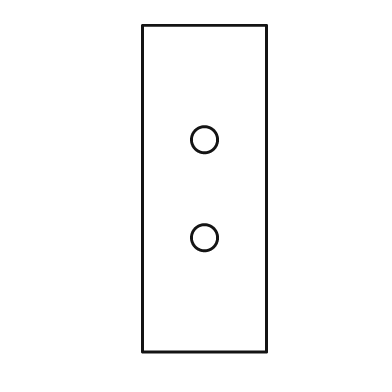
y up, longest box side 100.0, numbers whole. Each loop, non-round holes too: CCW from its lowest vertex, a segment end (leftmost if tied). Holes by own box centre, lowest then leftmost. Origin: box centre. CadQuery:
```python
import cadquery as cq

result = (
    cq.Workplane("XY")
    .moveTo(-19.0, -50.0)
    .lineTo(19.0, -50.0)
    .lineTo(19.0, 50.0)
    .lineTo(-19.0, 50.0)
    .close()
    .moveTo(0.0, -15.0)
    .circle(4.0)
    .moveTo(0.0, 15.0)
    .circle(4.0)
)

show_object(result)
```